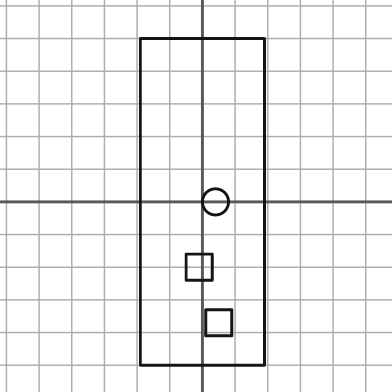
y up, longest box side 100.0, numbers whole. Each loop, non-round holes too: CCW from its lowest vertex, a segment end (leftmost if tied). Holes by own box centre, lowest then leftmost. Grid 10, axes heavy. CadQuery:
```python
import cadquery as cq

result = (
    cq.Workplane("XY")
    .moveTo(-19.0, -50.0)
    .lineTo(19.0, -50.0)
    .lineTo(19.0, 50.0)
    .lineTo(-19.0, 50.0)
    .close()
    .moveTo(1.0, -41.0)
    .lineTo(9.0, -41.0)
    .lineTo(9.0, -33.0)
    .lineTo(1.0, -33.0)
    .close()
    .moveTo(-5.0, -24.0)
    .lineTo(3.0, -24.0)
    .lineTo(3.0, -16.0)
    .lineTo(-5.0, -16.0)
    .close()
    .moveTo(4.0, 0.0)
    .circle(4.0)
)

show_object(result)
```